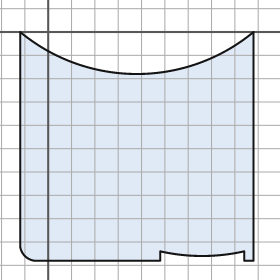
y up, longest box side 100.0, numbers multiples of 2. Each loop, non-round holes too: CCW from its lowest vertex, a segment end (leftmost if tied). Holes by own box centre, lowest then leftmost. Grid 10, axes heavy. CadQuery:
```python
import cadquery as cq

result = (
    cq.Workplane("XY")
    .moveTo(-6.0, -98.0)
    .lineTo(48.0, -98.0)
    .lineTo(48.0, -94.0)
    .threePointArc((66.0, -96.0), (84.0, -94.0))
    .lineTo(84.0, -98.0)
    .lineTo(88.0, -98.0)
    .lineTo(88.0, 0.0)
    .threePointArc((38.0, -18.0), (-12.0, 0.0))
    .lineTo(-12.0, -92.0)
    .threePointArc((-10.0, -96.0), (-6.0, -98.0))
    .close()
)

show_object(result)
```